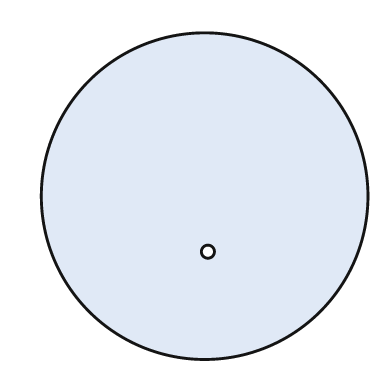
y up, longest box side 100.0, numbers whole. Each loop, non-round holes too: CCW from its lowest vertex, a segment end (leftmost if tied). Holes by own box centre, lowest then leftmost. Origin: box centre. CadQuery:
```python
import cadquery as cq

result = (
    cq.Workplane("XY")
    .moveTo(0.0, 0.0)
    .circle(50.0)
    .moveTo(1.0, -17.0)
    .circle(2.0)
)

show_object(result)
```